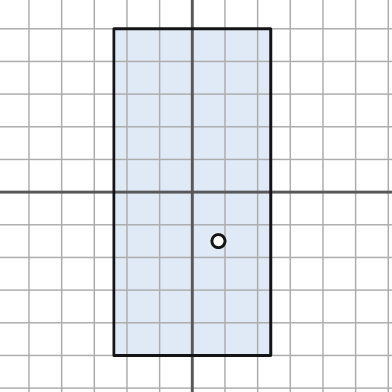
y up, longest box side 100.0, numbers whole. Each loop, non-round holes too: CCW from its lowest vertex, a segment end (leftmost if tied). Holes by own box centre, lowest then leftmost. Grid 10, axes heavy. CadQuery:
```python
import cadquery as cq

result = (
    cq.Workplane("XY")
    .moveTo(-24.0, -50.0)
    .lineTo(24.0, -50.0)
    .lineTo(24.0, 50.0)
    .lineTo(-24.0, 50.0)
    .close()
    .moveTo(8.0, -15.0)
    .circle(2.0)
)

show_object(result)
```